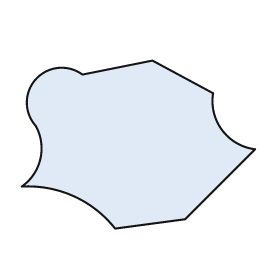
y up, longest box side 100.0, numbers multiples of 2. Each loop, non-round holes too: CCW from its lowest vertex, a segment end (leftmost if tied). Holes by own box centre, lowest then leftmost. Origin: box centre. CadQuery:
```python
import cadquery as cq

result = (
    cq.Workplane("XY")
    .moveTo(-10.0, -36.0)
    .lineTo(20.0, -32.0)
    .lineTo(50.0, -2.0)
    .threePointArc((36.0, 6.0), (32.0, 22.0))
    .lineTo(6.0, 36.0)
    .lineTo(-24.0, 30.0)
    .threePointArc((-44.0, 28.0), (-44.0, 8.0))
    .threePointArc((-42.0, -6.0), (-50.0, -18.0))
    .threePointArc((-28.0, -22.0), (-10.0, -36.0))
    .close()
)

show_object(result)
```